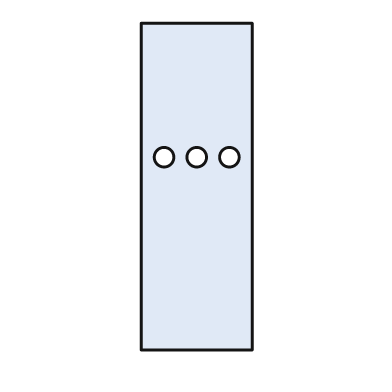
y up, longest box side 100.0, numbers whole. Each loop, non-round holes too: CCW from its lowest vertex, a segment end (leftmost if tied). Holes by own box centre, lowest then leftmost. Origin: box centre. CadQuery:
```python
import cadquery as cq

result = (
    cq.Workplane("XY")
    .moveTo(-17.0, -50.0)
    .lineTo(17.0, -50.0)
    .lineTo(17.0, 50.0)
    .lineTo(-17.0, 50.0)
    .close()
    .moveTo(-10.0, 9.0)
    .circle(3.0)
    .moveTo(0.0, 9.0)
    .circle(3.0)
    .moveTo(10.0, 9.0)
    .circle(3.0)
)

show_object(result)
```